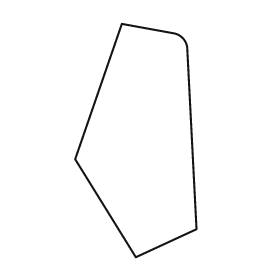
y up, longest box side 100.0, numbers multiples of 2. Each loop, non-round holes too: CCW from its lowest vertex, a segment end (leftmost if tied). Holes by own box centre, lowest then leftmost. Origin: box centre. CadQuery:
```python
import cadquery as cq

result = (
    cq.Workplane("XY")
    .moveTo(0.0, -50.0)
    .lineTo(26.0, -38.0)
    .lineTo(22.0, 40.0)
    .threePointArc((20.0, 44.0), (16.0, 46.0))
    .lineTo(-6.0, 50.0)
    .lineTo(-26.0, -8.0)
    .close()
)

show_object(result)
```